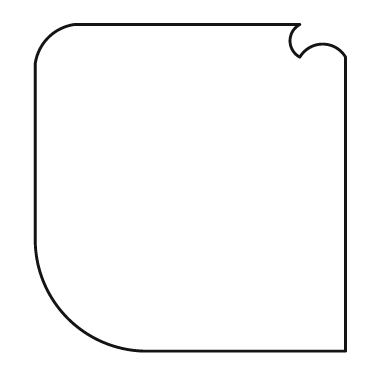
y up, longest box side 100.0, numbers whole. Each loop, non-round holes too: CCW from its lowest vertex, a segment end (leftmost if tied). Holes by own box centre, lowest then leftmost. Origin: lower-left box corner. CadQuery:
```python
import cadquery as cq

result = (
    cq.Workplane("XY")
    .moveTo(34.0, 0.0)
    .lineTo(95.0, 0.0)
    .lineTo(95.0, 90.0)
    .threePointArc((88.0, 94.0), (81.0, 90.0))
    .threePointArc((78.0, 95.0), (81.0, 100.0))
    .lineTo(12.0, 100.0)
    .threePointArc((4.0, 96.0), (0.0, 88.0))
    .lineTo(0.0, 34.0)
    .threePointArc((10.0, 10.0), (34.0, 0.0))
    .close()
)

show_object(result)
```